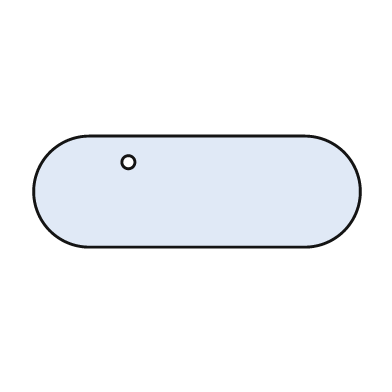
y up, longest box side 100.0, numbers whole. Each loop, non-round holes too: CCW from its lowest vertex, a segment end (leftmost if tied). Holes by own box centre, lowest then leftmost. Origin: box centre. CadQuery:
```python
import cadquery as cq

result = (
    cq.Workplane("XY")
    .moveTo(-33.0, -17.0)
    .lineTo(33.0, -17.0)
    .threePointArc((50.0, 0.0), (33.0, 17.0))
    .lineTo(-33.0, 17.0)
    .threePointArc((-50.0, 0.0), (-33.0, -17.0))
    .close()
    .moveTo(-21.0, 9.0)
    .circle(2.0)
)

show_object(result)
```